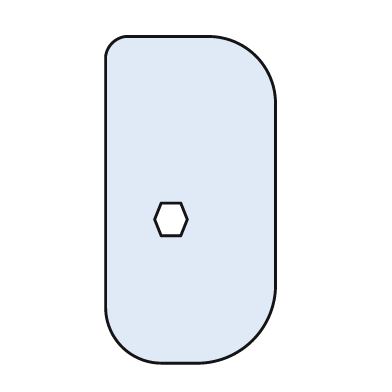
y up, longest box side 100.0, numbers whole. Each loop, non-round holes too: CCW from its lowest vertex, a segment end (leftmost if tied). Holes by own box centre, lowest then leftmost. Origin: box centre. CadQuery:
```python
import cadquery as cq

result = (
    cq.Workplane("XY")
    .moveTo(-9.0, -50.0)
    .lineTo(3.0, -50.0)
    .threePointArc((19.0, -43.0), (26.0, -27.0))
    .lineTo(26.0, 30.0)
    .threePointArc((20.0, 44.0), (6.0, 50.0))
    .lineTo(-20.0, 50.0)
    .threePointArc((-24.0, 48.0), (-26.0, 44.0))
    .lineTo(-26.0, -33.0)
    .threePointArc((-21.0, -45.0), (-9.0, -50.0))
    .close()
    .moveTo(-9.0, -11.0)
    .lineTo(-3.0, -11.0)
    .lineTo(-1.0, -6.0)
    .lineTo(-3.0, -1.0)
    .lineTo(-9.0, -1.0)
    .lineTo(-11.0, -6.0)
    .close()
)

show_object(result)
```